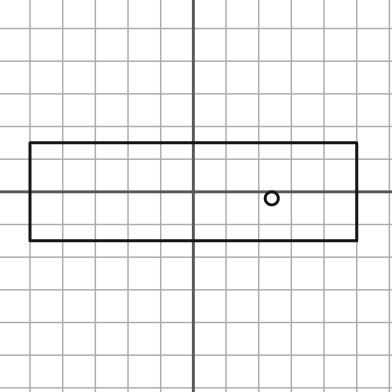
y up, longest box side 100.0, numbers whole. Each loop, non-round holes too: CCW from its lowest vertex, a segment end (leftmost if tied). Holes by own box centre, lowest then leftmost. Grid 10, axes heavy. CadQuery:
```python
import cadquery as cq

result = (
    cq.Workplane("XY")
    .moveTo(-50.0, -15.0)
    .lineTo(50.0, -15.0)
    .lineTo(50.0, 15.0)
    .lineTo(-50.0, 15.0)
    .close()
    .moveTo(24.0, -2.0)
    .circle(2.0)
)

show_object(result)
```